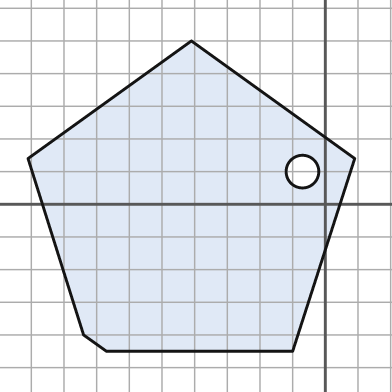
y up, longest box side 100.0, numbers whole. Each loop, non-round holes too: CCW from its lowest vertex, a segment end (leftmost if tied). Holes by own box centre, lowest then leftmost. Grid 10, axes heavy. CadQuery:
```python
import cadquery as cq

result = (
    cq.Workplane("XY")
    .moveTo(-67.0, -45.0)
    .lineTo(-10.0, -45.0)
    .lineTo(9.0, 14.0)
    .lineTo(-41.0, 50.0)
    .lineTo(-91.0, 14.0)
    .lineTo(-74.0, -40.0)
    .close()
    .moveTo(-7.0, 10.0)
    .circle(5.0)
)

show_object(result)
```